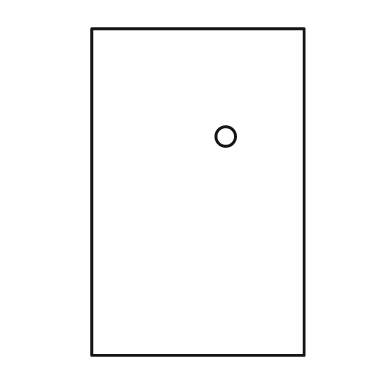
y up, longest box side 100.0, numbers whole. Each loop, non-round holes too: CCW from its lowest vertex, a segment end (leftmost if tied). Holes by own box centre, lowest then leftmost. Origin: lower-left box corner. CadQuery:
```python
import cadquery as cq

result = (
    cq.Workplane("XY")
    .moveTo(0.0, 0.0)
    .lineTo(65.0, 0.0)
    .lineTo(65.0, 100.0)
    .lineTo(0.0, 100.0)
    .close()
    .moveTo(41.0, 67.0)
    .circle(3.0)
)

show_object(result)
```